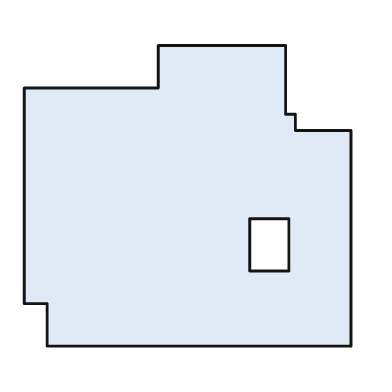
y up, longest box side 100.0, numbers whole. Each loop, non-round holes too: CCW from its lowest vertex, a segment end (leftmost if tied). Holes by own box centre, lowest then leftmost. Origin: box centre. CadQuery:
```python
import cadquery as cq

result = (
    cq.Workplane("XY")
    .moveTo(-43.0, -46.0)
    .lineTo(50.0, -46.0)
    .lineTo(50.0, 20.0)
    .lineTo(33.0, 20.0)
    .lineTo(33.0, 25.0)
    .lineTo(30.0, 25.0)
    .lineTo(30.0, 46.0)
    .lineTo(-9.0, 46.0)
    .lineTo(-9.0, 33.0)
    .lineTo(-50.0, 33.0)
    .lineTo(-50.0, -33.0)
    .lineTo(-43.0, -33.0)
    .close()
    .moveTo(19.0, -23.0)
    .lineTo(31.0, -23.0)
    .lineTo(31.0, -7.0)
    .lineTo(19.0, -7.0)
    .close()
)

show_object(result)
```